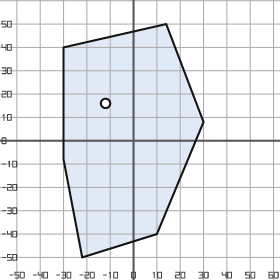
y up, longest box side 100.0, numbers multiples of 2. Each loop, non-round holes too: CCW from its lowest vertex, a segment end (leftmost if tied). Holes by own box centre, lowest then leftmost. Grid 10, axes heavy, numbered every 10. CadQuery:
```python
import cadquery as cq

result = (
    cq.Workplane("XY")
    .moveTo(-22.0, -50.0)
    .lineTo(10.0, -40.0)
    .lineTo(30.0, 8.0)
    .lineTo(14.0, 50.0)
    .lineTo(-30.0, 40.0)
    .lineTo(-30.0, -8.0)
    .close()
    .moveTo(-12.0, 16.0)
    .circle(2.0)
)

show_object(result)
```